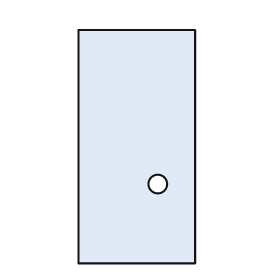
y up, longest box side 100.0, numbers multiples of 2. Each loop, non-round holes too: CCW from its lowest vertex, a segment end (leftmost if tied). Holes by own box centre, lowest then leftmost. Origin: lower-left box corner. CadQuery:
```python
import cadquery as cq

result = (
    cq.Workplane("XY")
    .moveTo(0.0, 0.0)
    .lineTo(50.0, 0.0)
    .lineTo(50.0, 100.0)
    .lineTo(0.0, 100.0)
    .close()
    .moveTo(34.0, 34.0)
    .circle(4.0)
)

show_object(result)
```